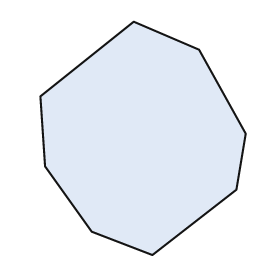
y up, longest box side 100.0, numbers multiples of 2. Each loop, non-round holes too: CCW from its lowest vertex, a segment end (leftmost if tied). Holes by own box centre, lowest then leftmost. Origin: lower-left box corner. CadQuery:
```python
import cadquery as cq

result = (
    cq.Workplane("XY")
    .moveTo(48.0, 0.0)
    .lineTo(84.0, 28.0)
    .lineTo(88.0, 52.0)
    .lineTo(68.0, 88.0)
    .lineTo(40.0, 100.0)
    .lineTo(0.0, 68.0)
    .lineTo(2.0, 38.0)
    .lineTo(22.0, 10.0)
    .close()
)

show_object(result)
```